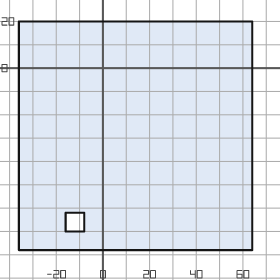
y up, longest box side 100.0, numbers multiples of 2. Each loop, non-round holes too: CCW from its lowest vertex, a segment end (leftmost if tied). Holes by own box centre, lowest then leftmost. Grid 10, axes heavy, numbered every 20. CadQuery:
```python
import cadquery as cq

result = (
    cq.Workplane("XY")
    .moveTo(-36.0, -78.0)
    .lineTo(64.0, -78.0)
    .lineTo(64.0, 20.0)
    .lineTo(-36.0, 20.0)
    .close()
    .moveTo(-16.0, -70.0)
    .lineTo(-8.0, -70.0)
    .lineTo(-8.0, -62.0)
    .lineTo(-16.0, -62.0)
    .close()
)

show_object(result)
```